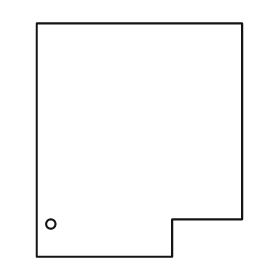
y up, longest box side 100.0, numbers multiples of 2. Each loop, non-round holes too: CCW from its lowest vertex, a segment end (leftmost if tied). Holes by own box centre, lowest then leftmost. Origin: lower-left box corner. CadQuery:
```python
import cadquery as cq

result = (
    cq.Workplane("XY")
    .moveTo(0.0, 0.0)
    .lineTo(58.0, 0.0)
    .lineTo(58.0, 16.0)
    .lineTo(88.0, 16.0)
    .lineTo(88.0, 100.0)
    .lineTo(0.0, 100.0)
    .close()
    .moveTo(6.0, 14.0)
    .circle(2.0)
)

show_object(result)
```